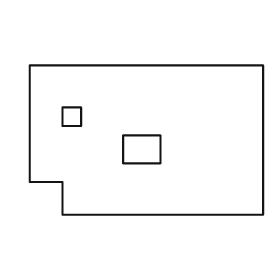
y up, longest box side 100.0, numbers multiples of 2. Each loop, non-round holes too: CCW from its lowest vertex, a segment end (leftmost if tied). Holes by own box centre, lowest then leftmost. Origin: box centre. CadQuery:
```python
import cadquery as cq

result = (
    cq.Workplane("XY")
    .moveTo(-36.0, -32.0)
    .lineTo(50.0, -32.0)
    .lineTo(50.0, 32.0)
    .lineTo(-50.0, 32.0)
    .lineTo(-50.0, -18.0)
    .lineTo(-36.0, -18.0)
    .close()
    .moveTo(-10.0, -10.0)
    .lineTo(6.0, -10.0)
    .lineTo(6.0, 2.0)
    .lineTo(-10.0, 2.0)
    .close()
    .moveTo(-36.0, 6.0)
    .lineTo(-28.0, 6.0)
    .lineTo(-28.0, 14.0)
    .lineTo(-36.0, 14.0)
    .close()
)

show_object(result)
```